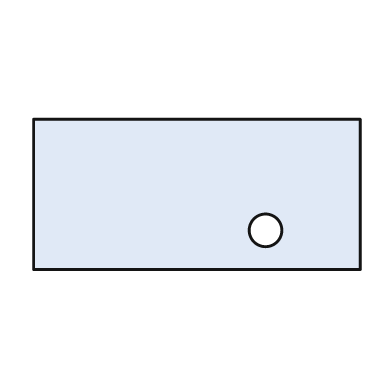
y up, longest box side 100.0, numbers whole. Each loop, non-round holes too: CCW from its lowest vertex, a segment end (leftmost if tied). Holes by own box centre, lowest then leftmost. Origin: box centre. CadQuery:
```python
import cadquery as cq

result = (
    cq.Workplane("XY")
    .moveTo(-50.0, -23.0)
    .lineTo(50.0, -23.0)
    .lineTo(50.0, 23.0)
    .lineTo(-50.0, 23.0)
    .close()
    .moveTo(21.0, -11.0)
    .circle(5.0)
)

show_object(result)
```